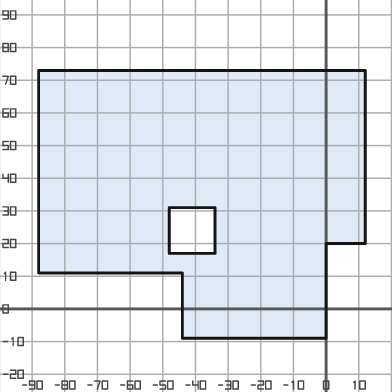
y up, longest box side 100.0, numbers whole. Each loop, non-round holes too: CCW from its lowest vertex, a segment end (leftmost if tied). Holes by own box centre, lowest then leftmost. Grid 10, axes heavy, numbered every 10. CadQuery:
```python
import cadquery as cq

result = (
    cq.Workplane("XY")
    .moveTo(-44.0, -9.0)
    .lineTo(0.0, -9.0)
    .lineTo(0.0, 20.0)
    .lineTo(12.0, 20.0)
    .lineTo(12.0, 73.0)
    .lineTo(-88.0, 73.0)
    .lineTo(-88.0, 11.0)
    .lineTo(-44.0, 11.0)
    .close()
    .moveTo(-48.0, 17.0)
    .lineTo(-34.0, 17.0)
    .lineTo(-34.0, 31.0)
    .lineTo(-48.0, 31.0)
    .close()
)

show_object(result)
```